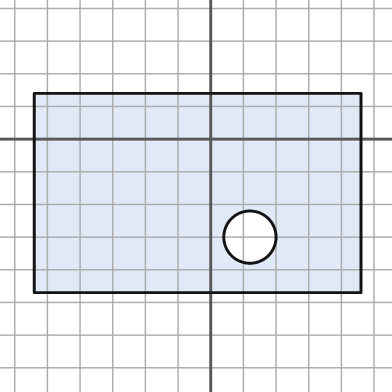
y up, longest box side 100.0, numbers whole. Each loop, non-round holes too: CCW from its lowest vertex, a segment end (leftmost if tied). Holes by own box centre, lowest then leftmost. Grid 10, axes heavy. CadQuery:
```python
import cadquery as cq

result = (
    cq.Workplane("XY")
    .moveTo(-54.0, -47.0)
    .lineTo(46.0, -47.0)
    .lineTo(46.0, 14.0)
    .lineTo(-54.0, 14.0)
    .close()
    .moveTo(12.0, -30.0)
    .circle(8.0)
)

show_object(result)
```